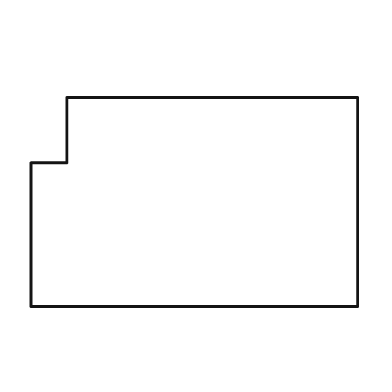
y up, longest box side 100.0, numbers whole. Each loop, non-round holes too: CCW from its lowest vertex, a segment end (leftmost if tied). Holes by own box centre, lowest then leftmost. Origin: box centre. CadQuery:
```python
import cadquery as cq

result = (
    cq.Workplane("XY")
    .moveTo(-50.0, -32.0)
    .lineTo(50.0, -32.0)
    .lineTo(50.0, 32.0)
    .lineTo(-39.0, 32.0)
    .lineTo(-39.0, 12.0)
    .lineTo(-50.0, 12.0)
    .close()
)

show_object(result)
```